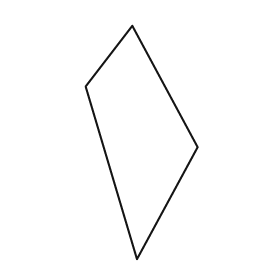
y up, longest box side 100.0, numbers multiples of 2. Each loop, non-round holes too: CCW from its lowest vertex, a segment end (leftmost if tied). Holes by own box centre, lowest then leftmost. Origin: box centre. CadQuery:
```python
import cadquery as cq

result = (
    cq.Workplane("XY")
    .moveTo(-2.0, -50.0)
    .lineTo(24.0, -2.0)
    .lineTo(-4.0, 50.0)
    .lineTo(-24.0, 24.0)
    .close()
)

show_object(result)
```